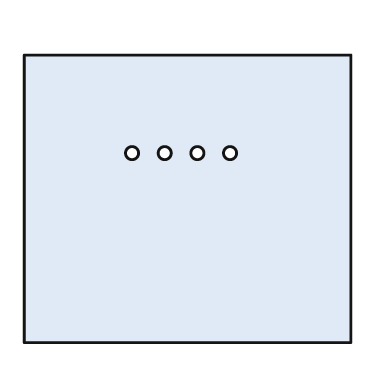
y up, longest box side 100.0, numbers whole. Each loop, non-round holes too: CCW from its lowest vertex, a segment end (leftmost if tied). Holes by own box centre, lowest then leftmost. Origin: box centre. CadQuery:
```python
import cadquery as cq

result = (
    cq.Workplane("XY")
    .moveTo(-50.0, -44.0)
    .lineTo(50.0, -44.0)
    .lineTo(50.0, 44.0)
    .lineTo(-50.0, 44.0)
    .close()
    .moveTo(-17.0, 14.0)
    .circle(2.0)
    .moveTo(-7.0, 14.0)
    .circle(2.0)
    .moveTo(3.0, 14.0)
    .circle(2.0)
    .moveTo(13.0, 14.0)
    .circle(2.0)
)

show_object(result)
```